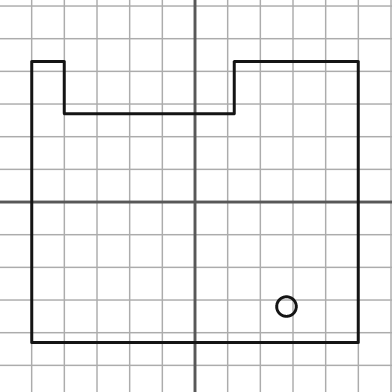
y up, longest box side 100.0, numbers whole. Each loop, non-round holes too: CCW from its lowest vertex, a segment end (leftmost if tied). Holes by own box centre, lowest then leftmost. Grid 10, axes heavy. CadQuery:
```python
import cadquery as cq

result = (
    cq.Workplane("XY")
    .moveTo(-50.0, -43.0)
    .lineTo(50.0, -43.0)
    .lineTo(50.0, 43.0)
    .lineTo(12.0, 43.0)
    .lineTo(12.0, 27.0)
    .lineTo(-40.0, 27.0)
    .lineTo(-40.0, 43.0)
    .lineTo(-50.0, 43.0)
    .close()
    .moveTo(28.0, -32.0)
    .circle(3.0)
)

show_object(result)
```